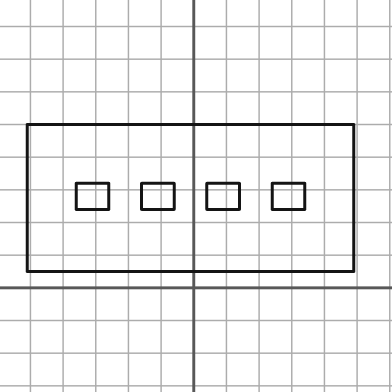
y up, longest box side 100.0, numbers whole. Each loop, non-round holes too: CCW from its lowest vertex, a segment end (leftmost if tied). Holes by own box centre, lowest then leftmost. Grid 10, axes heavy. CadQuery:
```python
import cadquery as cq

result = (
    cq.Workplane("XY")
    .moveTo(-51.0, 5.0)
    .lineTo(49.0, 5.0)
    .lineTo(49.0, 50.0)
    .lineTo(-51.0, 50.0)
    .close()
    .moveTo(-36.0, 24.0)
    .lineTo(-26.0, 24.0)
    .lineTo(-26.0, 32.0)
    .lineTo(-36.0, 32.0)
    .close()
    .moveTo(-16.0, 24.0)
    .lineTo(-6.0, 24.0)
    .lineTo(-6.0, 32.0)
    .lineTo(-16.0, 32.0)
    .close()
    .moveTo(4.0, 24.0)
    .lineTo(14.0, 24.0)
    .lineTo(14.0, 32.0)
    .lineTo(4.0, 32.0)
    .close()
    .moveTo(24.0, 24.0)
    .lineTo(34.0, 24.0)
    .lineTo(34.0, 32.0)
    .lineTo(24.0, 32.0)
    .close()
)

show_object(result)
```